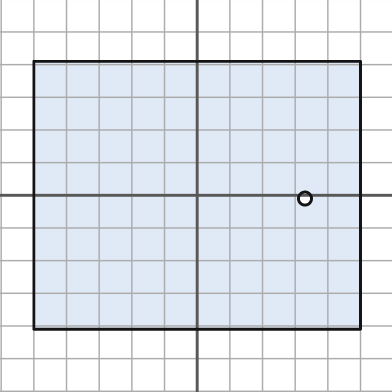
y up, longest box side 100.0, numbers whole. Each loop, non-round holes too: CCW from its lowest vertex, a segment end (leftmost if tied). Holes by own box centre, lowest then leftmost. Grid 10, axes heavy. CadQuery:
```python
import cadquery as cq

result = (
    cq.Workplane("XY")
    .moveTo(-50.0, -41.0)
    .lineTo(50.0, -41.0)
    .lineTo(50.0, 41.0)
    .lineTo(-50.0, 41.0)
    .close()
    .moveTo(33.0, -1.0)
    .circle(2.0)
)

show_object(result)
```